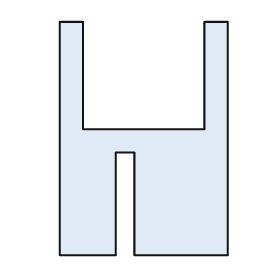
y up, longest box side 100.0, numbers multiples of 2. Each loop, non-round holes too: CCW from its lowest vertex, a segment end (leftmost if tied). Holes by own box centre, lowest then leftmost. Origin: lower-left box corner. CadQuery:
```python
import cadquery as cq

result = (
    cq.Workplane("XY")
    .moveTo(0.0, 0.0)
    .lineTo(24.0, 0.0)
    .lineTo(24.0, 44.0)
    .lineTo(32.0, 44.0)
    .lineTo(32.0, 0.0)
    .lineTo(72.0, 0.0)
    .lineTo(72.0, 100.0)
    .lineTo(62.0, 100.0)
    .lineTo(62.0, 54.0)
    .lineTo(10.0, 54.0)
    .lineTo(10.0, 100.0)
    .lineTo(0.0, 100.0)
    .close()
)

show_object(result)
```